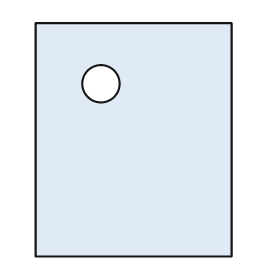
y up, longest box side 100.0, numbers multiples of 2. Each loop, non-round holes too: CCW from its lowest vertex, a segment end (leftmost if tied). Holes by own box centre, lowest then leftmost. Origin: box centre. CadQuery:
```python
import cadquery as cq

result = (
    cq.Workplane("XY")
    .moveTo(-42.0, -50.0)
    .lineTo(42.0, -50.0)
    .lineTo(42.0, 50.0)
    .lineTo(-42.0, 50.0)
    .close()
    .moveTo(-14.0, 24.0)
    .circle(8.0)
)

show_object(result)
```